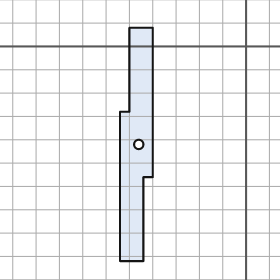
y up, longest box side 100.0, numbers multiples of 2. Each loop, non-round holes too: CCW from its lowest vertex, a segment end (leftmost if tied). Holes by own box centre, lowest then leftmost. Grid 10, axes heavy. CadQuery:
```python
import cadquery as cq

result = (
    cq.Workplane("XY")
    .moveTo(-54.0, -92.0)
    .lineTo(-44.0, -92.0)
    .lineTo(-44.0, -56.0)
    .lineTo(-40.0, -56.0)
    .lineTo(-40.0, 8.0)
    .lineTo(-50.0, 8.0)
    .lineTo(-50.0, -28.0)
    .lineTo(-54.0, -28.0)
    .close()
    .moveTo(-46.0, -42.0)
    .circle(2.0)
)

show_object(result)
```